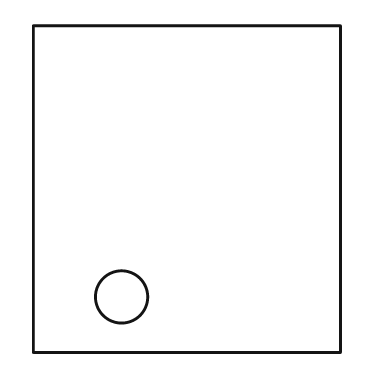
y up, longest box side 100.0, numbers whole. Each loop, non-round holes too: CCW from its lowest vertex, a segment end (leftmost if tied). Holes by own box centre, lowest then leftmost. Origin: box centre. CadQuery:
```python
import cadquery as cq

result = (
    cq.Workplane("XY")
    .moveTo(-47.0, -50.0)
    .lineTo(47.0, -50.0)
    .lineTo(47.0, 50.0)
    .lineTo(-47.0, 50.0)
    .close()
    .moveTo(-20.0, -33.0)
    .circle(8.0)
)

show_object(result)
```